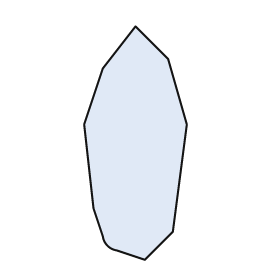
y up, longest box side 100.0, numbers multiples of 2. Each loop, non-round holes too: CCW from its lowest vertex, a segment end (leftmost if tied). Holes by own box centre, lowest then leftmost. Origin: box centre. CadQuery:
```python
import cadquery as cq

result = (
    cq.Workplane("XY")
    .moveTo(4.0, -50.0)
    .lineTo(16.0, -38.0)
    .lineTo(22.0, 8.0)
    .lineTo(14.0, 36.0)
    .lineTo(0.0, 50.0)
    .lineTo(-14.0, 32.0)
    .lineTo(-22.0, 8.0)
    .lineTo(-18.0, -28.0)
    .lineTo(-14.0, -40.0)
    .threePointArc((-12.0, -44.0), (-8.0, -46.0))
    .close()
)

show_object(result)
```